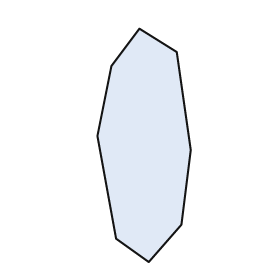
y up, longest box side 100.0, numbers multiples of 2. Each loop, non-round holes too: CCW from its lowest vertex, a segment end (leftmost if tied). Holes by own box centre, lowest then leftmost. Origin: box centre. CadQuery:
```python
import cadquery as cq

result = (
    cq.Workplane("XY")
    .moveTo(2.0, -50.0)
    .lineTo(16.0, -34.0)
    .lineTo(20.0, -2.0)
    .lineTo(14.0, 40.0)
    .lineTo(-2.0, 50.0)
    .lineTo(-14.0, 34.0)
    .lineTo(-20.0, 4.0)
    .lineTo(-12.0, -40.0)
    .close()
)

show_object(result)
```